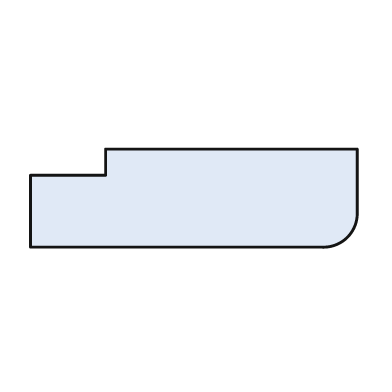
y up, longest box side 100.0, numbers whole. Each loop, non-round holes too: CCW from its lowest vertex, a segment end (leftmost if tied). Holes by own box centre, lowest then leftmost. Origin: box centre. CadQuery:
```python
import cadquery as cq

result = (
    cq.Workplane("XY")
    .moveTo(-50.0, -15.0)
    .lineTo(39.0, -15.0)
    .threePointArc((47.0, -12.0), (50.0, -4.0))
    .lineTo(50.0, 15.0)
    .lineTo(-27.0, 15.0)
    .lineTo(-27.0, 7.0)
    .lineTo(-50.0, 7.0)
    .close()
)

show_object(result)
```